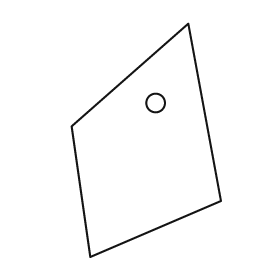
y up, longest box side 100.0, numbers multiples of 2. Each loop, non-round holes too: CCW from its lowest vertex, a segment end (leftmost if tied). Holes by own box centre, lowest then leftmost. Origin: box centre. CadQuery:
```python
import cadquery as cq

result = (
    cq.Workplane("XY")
    .moveTo(-24.0, -50.0)
    .lineTo(32.0, -26.0)
    .lineTo(18.0, 50.0)
    .lineTo(-32.0, 6.0)
    .close()
    .moveTo(4.0, 16.0)
    .circle(4.0)
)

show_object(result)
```